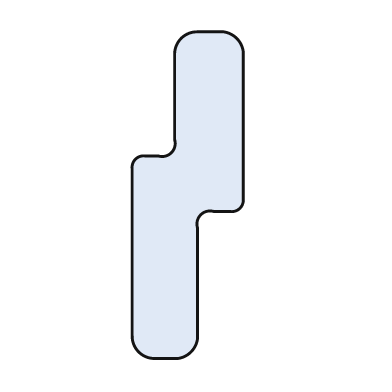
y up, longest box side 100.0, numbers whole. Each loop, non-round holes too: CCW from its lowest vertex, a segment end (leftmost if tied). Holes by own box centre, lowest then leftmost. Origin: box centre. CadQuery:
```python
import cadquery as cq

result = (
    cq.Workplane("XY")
    .moveTo(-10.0, -50.0)
    .lineTo(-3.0, -50.0)
    .threePointArc((1.0, -48.0), (3.0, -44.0))
    .lineTo(3.0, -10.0)
    .threePointArc((4.0, -6.0), (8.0, -5.0))
    .lineTo(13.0, -5.0)
    .threePointArc((16.0, -4.0), (17.0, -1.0))
    .lineTo(17.0, 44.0)
    .threePointArc((15.0, 48.0), (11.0, 50.0))
    .lineTo(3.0, 50.0)
    .threePointArc((-2.0, 48.0), (-4.0, 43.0))
    .lineTo(-4.0, 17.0)
    .threePointArc((-5.0, 13.0), (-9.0, 12.0))
    .lineTo(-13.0, 12.0)
    .threePointArc((-16.0, 11.0), (-17.0, 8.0))
    .lineTo(-17.0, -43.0)
    .threePointArc((-15.0, -48.0), (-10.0, -50.0))
    .close()
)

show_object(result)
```